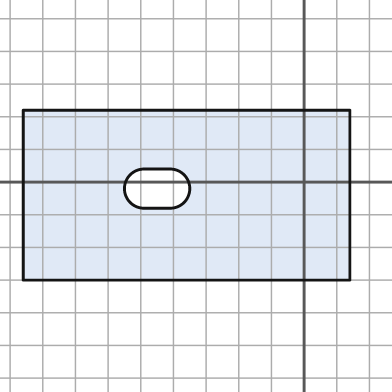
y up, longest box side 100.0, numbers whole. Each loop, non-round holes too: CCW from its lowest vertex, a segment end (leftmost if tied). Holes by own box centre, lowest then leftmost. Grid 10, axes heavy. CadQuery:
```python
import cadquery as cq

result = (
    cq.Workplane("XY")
    .moveTo(-86.0, -30.0)
    .lineTo(14.0, -30.0)
    .lineTo(14.0, 22.0)
    .lineTo(-86.0, 22.0)
    .close()
    .moveTo(-49.0, -8.0)
    .lineTo(-41.0, -8.0)
    .threePointArc((-35.0, -2.0), (-41.0, 4.0))
    .lineTo(-49.0, 4.0)
    .threePointArc((-55.0, -2.0), (-49.0, -8.0))
    .close()
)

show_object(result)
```